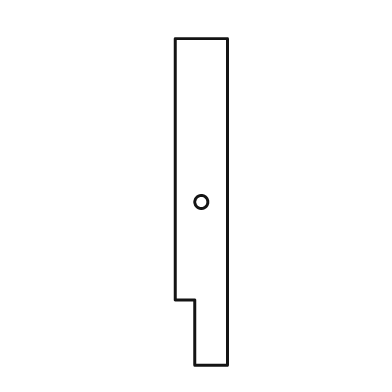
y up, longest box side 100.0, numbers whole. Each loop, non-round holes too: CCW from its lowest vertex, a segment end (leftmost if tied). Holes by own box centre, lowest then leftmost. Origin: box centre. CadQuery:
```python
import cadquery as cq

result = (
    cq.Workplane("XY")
    .moveTo(-2.0, -50.0)
    .lineTo(8.0, -50.0)
    .lineTo(8.0, 50.0)
    .lineTo(-8.0, 50.0)
    .lineTo(-8.0, -30.0)
    .lineTo(-2.0, -30.0)
    .close()
    .moveTo(0.0, 0.0)
    .circle(2.0)
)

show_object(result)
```